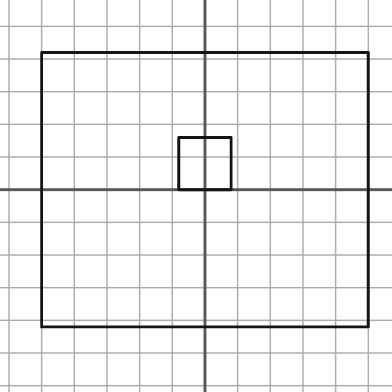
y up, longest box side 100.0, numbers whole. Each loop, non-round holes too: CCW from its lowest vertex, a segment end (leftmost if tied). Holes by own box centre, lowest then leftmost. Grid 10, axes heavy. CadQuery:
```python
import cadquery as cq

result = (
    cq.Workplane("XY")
    .moveTo(-50.0, -42.0)
    .lineTo(50.0, -42.0)
    .lineTo(50.0, 42.0)
    .lineTo(-50.0, 42.0)
    .close()
    .moveTo(-8.0, 0.0)
    .lineTo(8.0, 0.0)
    .lineTo(8.0, 16.0)
    .lineTo(-8.0, 16.0)
    .close()
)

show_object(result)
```